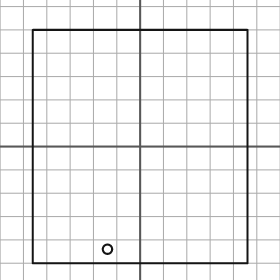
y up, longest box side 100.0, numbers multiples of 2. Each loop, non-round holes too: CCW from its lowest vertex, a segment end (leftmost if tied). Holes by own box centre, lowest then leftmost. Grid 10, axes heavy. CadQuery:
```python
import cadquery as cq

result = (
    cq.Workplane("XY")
    .moveTo(-46.0, -50.0)
    .lineTo(46.0, -50.0)
    .lineTo(46.0, 50.0)
    .lineTo(-46.0, 50.0)
    .close()
    .moveTo(-14.0, -44.0)
    .circle(2.0)
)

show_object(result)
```